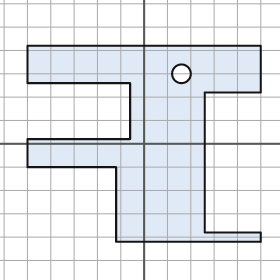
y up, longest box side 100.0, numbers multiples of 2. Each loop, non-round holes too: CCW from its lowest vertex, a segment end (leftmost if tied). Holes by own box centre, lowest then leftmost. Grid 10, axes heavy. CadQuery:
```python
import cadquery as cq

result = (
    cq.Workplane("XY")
    .moveTo(-12.0, -42.0)
    .lineTo(50.0, -42.0)
    .lineTo(50.0, -38.0)
    .lineTo(26.0, -38.0)
    .lineTo(26.0, 22.0)
    .lineTo(50.0, 22.0)
    .lineTo(50.0, 42.0)
    .lineTo(-50.0, 42.0)
    .lineTo(-50.0, 26.0)
    .lineTo(-6.0, 26.0)
    .lineTo(-6.0, 2.0)
    .lineTo(-50.0, 2.0)
    .lineTo(-50.0, -10.0)
    .lineTo(-12.0, -10.0)
    .close()
    .moveTo(16.0, 30.0)
    .circle(4.0)
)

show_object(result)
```